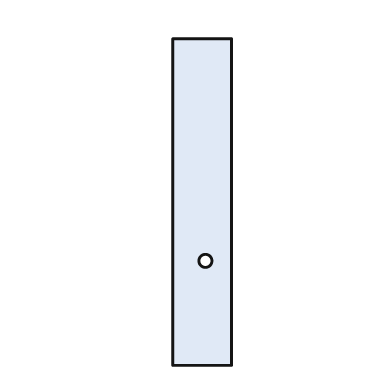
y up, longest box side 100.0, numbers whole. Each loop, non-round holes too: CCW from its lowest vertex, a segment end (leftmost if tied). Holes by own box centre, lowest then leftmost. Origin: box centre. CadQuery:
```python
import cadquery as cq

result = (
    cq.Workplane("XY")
    .moveTo(-9.0, -50.0)
    .lineTo(9.0, -50.0)
    .lineTo(9.0, 50.0)
    .lineTo(-9.0, 50.0)
    .close()
    .moveTo(1.0, -18.0)
    .circle(2.0)
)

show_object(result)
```